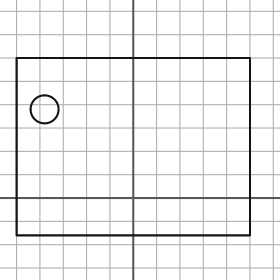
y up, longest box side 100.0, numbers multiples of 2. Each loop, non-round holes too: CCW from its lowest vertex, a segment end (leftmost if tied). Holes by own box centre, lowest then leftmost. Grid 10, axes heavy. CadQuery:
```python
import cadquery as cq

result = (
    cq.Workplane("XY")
    .moveTo(-50.0, -16.0)
    .lineTo(50.0, -16.0)
    .lineTo(50.0, 60.0)
    .lineTo(-50.0, 60.0)
    .close()
    .moveTo(-38.0, 38.0)
    .circle(6.0)
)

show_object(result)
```